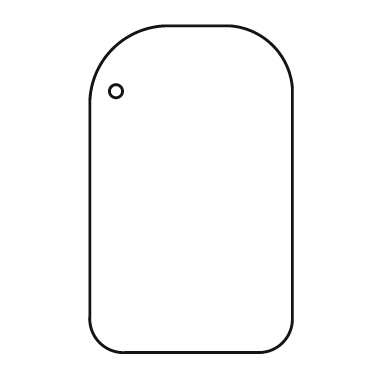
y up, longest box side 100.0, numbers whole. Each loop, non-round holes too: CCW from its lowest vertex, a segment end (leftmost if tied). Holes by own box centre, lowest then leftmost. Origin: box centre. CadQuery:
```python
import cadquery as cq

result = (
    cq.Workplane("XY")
    .moveTo(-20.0, -50.0)
    .lineTo(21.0, -50.0)
    .threePointArc((28.0, -47.0), (31.0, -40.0))
    .lineTo(31.0, 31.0)
    .threePointArc((25.0, 44.0), (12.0, 50.0))
    .lineTo(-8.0, 50.0)
    .threePointArc((-24.0, 43.0), (-31.0, 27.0))
    .lineTo(-31.0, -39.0)
    .threePointArc((-28.0, -47.0), (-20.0, -50.0))
    .close()
    .moveTo(-23.0, 30.0)
    .circle(2.0)
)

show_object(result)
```